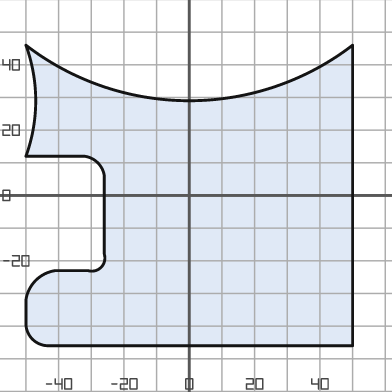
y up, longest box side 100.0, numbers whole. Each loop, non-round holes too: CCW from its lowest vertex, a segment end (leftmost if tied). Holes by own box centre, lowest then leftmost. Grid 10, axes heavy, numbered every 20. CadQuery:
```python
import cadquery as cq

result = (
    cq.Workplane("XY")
    .moveTo(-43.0, -46.0)
    .lineTo(50.0, -46.0)
    .lineTo(50.0, 46.0)
    .threePointArc((0.0, 29.0), (-50.0, 46.0))
    .threePointArc((-47.0, 29.0), (-50.0, 12.0))
    .lineTo(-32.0, 12.0)
    .threePointArc((-28.0, 10.0), (-26.0, 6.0))
    .lineTo(-26.0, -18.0)
    .threePointArc((-27.0, -22.0), (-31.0, -23.0))
    .lineTo(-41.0, -23.0)
    .threePointArc((-47.0, -26.0), (-50.0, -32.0))
    .lineTo(-50.0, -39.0)
    .threePointArc((-48.0, -44.0), (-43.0, -46.0))
    .close()
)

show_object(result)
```